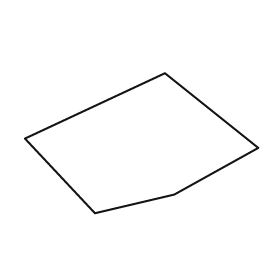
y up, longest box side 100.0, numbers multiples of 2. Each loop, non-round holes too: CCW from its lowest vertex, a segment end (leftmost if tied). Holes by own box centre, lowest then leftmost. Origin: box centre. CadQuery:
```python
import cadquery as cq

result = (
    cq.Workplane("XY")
    .moveTo(-20.0, -30.0)
    .lineTo(14.0, -22.0)
    .lineTo(50.0, -2.0)
    .lineTo(10.0, 30.0)
    .lineTo(-50.0, 2.0)
    .close()
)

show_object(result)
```